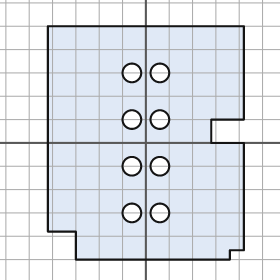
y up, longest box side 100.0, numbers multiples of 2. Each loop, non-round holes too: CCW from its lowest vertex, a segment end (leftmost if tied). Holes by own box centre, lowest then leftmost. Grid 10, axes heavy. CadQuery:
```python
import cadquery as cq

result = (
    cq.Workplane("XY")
    .moveTo(-30.0, -50.0)
    .lineTo(36.0, -50.0)
    .lineTo(36.0, -46.0)
    .lineTo(42.0, -46.0)
    .lineTo(42.0, 0.0)
    .lineTo(28.0, 0.0)
    .lineTo(28.0, 10.0)
    .lineTo(42.0, 10.0)
    .lineTo(42.0, 50.0)
    .lineTo(-42.0, 50.0)
    .lineTo(-42.0, -38.0)
    .lineTo(-30.0, -38.0)
    .close()
    .moveTo(-6.0, -30.0)
    .circle(4.0)
    .moveTo(6.0, -30.0)
    .circle(4.0)
    .moveTo(-6.0, -10.0)
    .circle(4.0)
    .moveTo(6.0, -10.0)
    .circle(4.0)
    .moveTo(-6.0, 10.0)
    .circle(4.0)
    .moveTo(6.0, 10.0)
    .circle(4.0)
    .moveTo(-6.0, 30.0)
    .circle(4.0)
    .moveTo(6.0, 30.0)
    .circle(4.0)
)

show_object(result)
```